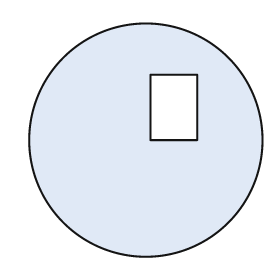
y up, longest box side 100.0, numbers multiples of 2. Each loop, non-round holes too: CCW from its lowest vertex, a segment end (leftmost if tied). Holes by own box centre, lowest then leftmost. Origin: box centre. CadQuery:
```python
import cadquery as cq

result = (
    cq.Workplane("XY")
    .moveTo(0.0, 0.0)
    .circle(50.0)
    .moveTo(2.0, 0.0)
    .lineTo(22.0, 0.0)
    .lineTo(22.0, 28.0)
    .lineTo(2.0, 28.0)
    .close()
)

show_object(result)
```